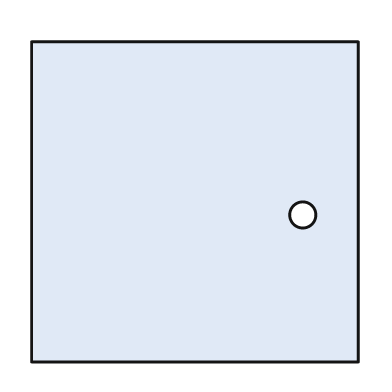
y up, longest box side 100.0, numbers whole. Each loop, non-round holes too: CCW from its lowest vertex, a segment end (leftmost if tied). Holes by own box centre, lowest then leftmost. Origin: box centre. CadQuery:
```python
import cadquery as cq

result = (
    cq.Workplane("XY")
    .moveTo(-50.0, -49.0)
    .lineTo(50.0, -49.0)
    .lineTo(50.0, 49.0)
    .lineTo(-50.0, 49.0)
    .close()
    .moveTo(33.0, -4.0)
    .circle(4.0)
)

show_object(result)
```